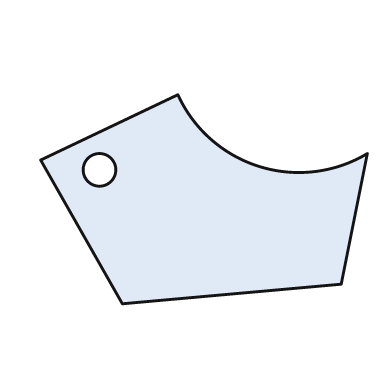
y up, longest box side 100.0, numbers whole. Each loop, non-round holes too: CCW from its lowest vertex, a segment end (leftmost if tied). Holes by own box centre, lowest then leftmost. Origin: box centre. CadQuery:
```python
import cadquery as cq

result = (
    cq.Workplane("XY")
    .moveTo(-25.0, -32.0)
    .lineTo(42.0, -26.0)
    .lineTo(50.0, 14.0)
    .threePointArc((17.0, 10.0), (-8.0, 32.0))
    .lineTo(-50.0, 12.0)
    .close()
    .moveTo(-32.0, 9.0)
    .circle(5.0)
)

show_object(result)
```